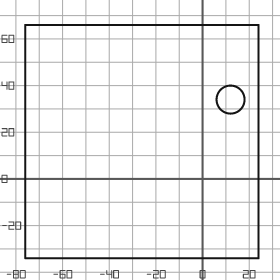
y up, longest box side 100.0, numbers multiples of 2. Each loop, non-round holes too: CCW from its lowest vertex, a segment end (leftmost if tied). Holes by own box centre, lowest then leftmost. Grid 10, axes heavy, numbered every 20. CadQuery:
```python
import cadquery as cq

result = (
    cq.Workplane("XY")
    .moveTo(-76.0, -34.0)
    .lineTo(24.0, -34.0)
    .lineTo(24.0, 66.0)
    .lineTo(-76.0, 66.0)
    .close()
    .moveTo(12.0, 34.0)
    .circle(6.0)
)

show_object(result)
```